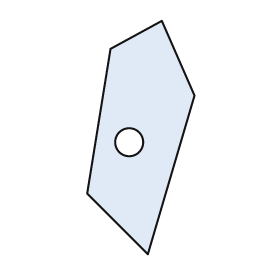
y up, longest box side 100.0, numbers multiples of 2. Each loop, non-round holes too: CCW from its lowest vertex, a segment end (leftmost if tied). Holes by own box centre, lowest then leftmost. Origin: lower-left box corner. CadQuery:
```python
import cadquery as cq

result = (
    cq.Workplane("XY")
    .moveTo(26.0, 0.0)
    .lineTo(46.0, 68.0)
    .lineTo(32.0, 100.0)
    .lineTo(10.0, 88.0)
    .lineTo(0.0, 26.0)
    .close()
    .moveTo(18.0, 48.0)
    .circle(6.0)
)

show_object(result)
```